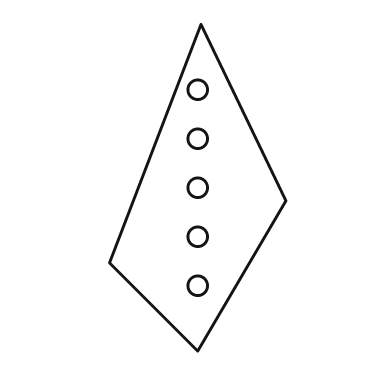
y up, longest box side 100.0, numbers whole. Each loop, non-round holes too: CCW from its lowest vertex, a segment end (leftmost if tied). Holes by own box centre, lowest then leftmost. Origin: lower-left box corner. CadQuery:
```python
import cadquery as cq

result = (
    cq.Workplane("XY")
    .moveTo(27.0, 0.0)
    .lineTo(54.0, 46.0)
    .lineTo(28.0, 100.0)
    .lineTo(0.0, 27.0)
    .close()
    .moveTo(27.0, 20.0)
    .circle(3.0)
    .moveTo(27.0, 35.0)
    .circle(3.0)
    .moveTo(27.0, 50.0)
    .circle(3.0)
    .moveTo(27.0, 65.0)
    .circle(3.0)
    .moveTo(27.0, 80.0)
    .circle(3.0)
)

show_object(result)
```